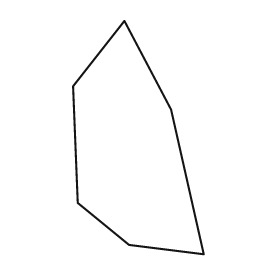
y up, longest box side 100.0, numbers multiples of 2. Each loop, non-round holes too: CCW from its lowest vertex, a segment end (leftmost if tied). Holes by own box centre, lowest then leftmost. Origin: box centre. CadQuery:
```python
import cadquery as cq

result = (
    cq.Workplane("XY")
    .moveTo(28.0, -50.0)
    .lineTo(14.0, 12.0)
    .lineTo(-6.0, 50.0)
    .lineTo(-28.0, 22.0)
    .lineTo(-26.0, -28.0)
    .lineTo(-4.0, -46.0)
    .close()
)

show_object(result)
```